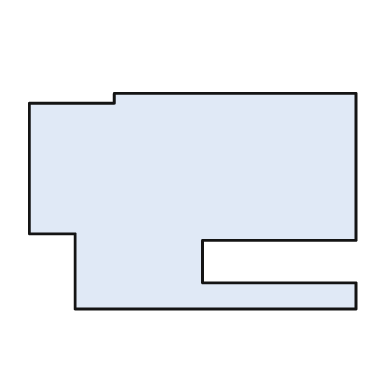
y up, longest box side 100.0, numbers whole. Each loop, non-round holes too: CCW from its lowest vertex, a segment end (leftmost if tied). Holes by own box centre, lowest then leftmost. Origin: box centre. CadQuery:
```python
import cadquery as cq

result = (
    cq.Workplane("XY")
    .moveTo(-36.0, -33.0)
    .lineTo(50.0, -33.0)
    .lineTo(50.0, -25.0)
    .lineTo(3.0, -25.0)
    .lineTo(3.0, -12.0)
    .lineTo(50.0, -12.0)
    .lineTo(50.0, 33.0)
    .lineTo(-24.0, 33.0)
    .lineTo(-24.0, 30.0)
    .lineTo(-50.0, 30.0)
    .lineTo(-50.0, -10.0)
    .lineTo(-36.0, -10.0)
    .close()
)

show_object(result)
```